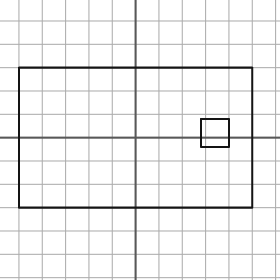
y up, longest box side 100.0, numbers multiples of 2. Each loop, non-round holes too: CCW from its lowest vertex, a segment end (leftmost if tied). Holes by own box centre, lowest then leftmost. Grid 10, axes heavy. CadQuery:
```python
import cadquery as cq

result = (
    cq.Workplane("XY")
    .moveTo(-50.0, -30.0)
    .lineTo(50.0, -30.0)
    .lineTo(50.0, 30.0)
    .lineTo(-50.0, 30.0)
    .close()
    .moveTo(28.0, -4.0)
    .lineTo(40.0, -4.0)
    .lineTo(40.0, 8.0)
    .lineTo(28.0, 8.0)
    .close()
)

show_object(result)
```